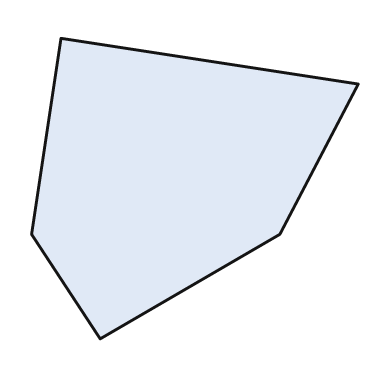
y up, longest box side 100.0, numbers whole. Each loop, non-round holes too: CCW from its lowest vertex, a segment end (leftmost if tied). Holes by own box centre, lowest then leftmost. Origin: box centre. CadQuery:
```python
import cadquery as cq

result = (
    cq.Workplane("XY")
    .moveTo(-29.0, -46.0)
    .lineTo(26.0, -14.0)
    .lineTo(50.0, 32.0)
    .lineTo(-41.0, 46.0)
    .lineTo(-50.0, -14.0)
    .close()
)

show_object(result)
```